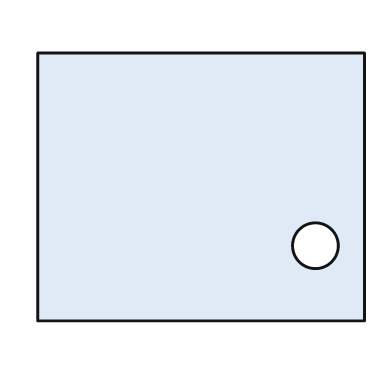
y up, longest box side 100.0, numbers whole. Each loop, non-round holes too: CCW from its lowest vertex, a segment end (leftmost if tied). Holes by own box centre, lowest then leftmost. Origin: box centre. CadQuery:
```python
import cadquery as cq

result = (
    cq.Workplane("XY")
    .moveTo(-50.0, -41.0)
    .lineTo(50.0, -41.0)
    .lineTo(50.0, 41.0)
    .lineTo(-50.0, 41.0)
    .close()
    .moveTo(35.0, -18.0)
    .circle(7.0)
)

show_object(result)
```